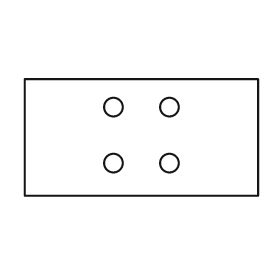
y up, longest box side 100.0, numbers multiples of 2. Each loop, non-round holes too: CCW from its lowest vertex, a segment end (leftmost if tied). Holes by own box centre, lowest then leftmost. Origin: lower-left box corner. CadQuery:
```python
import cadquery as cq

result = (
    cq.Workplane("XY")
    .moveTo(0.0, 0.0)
    .lineTo(100.0, 0.0)
    .lineTo(100.0, 50.0)
    .lineTo(0.0, 50.0)
    .close()
    .moveTo(38.0, 14.0)
    .circle(4.0)
    .moveTo(62.0, 14.0)
    .circle(4.0)
    .moveTo(38.0, 38.0)
    .circle(4.0)
    .moveTo(62.0, 38.0)
    .circle(4.0)
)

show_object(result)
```